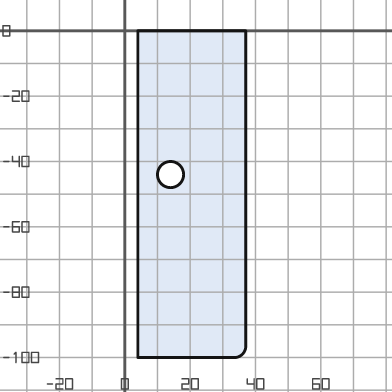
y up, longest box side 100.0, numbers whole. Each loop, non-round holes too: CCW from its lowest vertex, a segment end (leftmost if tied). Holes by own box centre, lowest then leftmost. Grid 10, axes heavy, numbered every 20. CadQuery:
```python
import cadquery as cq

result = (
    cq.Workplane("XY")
    .moveTo(4.0, -100.0)
    .lineTo(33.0, -100.0)
    .threePointArc((36.0, -99.0), (37.0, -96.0))
    .lineTo(37.0, 0.0)
    .lineTo(4.0, 0.0)
    .close()
    .moveTo(14.0, -44.0)
    .circle(4.0)
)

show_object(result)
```